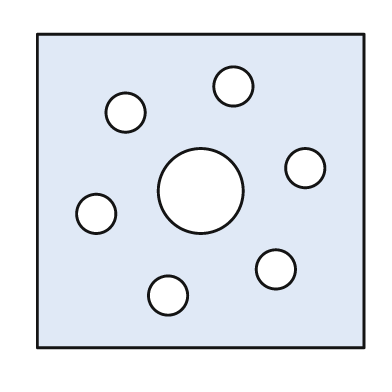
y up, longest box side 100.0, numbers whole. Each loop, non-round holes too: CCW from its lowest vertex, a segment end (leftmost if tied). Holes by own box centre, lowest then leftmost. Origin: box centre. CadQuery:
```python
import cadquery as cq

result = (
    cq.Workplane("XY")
    .moveTo(-50.0, -48.0)
    .lineTo(50.0, -48.0)
    .lineTo(50.0, 48.0)
    .lineTo(-50.0, 48.0)
    .close()
    .moveTo(-10.0, -32.0)
    .circle(6.0)
    .moveTo(23.0, -24.0)
    .circle(6.0)
    .moveTo(-32.0, -7.0)
    .circle(6.0)
    .moveTo(0.0, 0.0)
    .circle(13.0)
    .moveTo(32.0, 7.0)
    .circle(6.0)
    .moveTo(-23.0, 24.0)
    .circle(6.0)
    .moveTo(10.0, 32.0)
    .circle(6.0)
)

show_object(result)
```